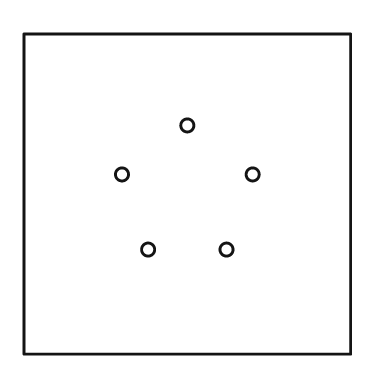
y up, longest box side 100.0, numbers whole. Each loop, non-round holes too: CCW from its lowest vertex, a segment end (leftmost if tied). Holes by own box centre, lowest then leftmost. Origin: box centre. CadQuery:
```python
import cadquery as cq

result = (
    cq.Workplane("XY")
    .moveTo(-50.0, -49.0)
    .lineTo(50.0, -49.0)
    .lineTo(50.0, 49.0)
    .lineTo(-50.0, 49.0)
    .close()
    .moveTo(-12.0, -17.0)
    .circle(2.0)
    .moveTo(12.0, -17.0)
    .circle(2.0)
    .moveTo(-20.0, 6.0)
    .circle(2.0)
    .moveTo(20.0, 6.0)
    .circle(2.0)
    .moveTo(0.0, 21.0)
    .circle(2.0)
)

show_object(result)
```